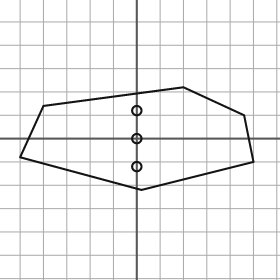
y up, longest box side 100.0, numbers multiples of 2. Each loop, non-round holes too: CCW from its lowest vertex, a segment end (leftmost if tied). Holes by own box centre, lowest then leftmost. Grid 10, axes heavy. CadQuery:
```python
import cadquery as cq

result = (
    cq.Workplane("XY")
    .moveTo(2.0, -22.0)
    .lineTo(50.0, -10.0)
    .lineTo(46.0, 10.0)
    .lineTo(20.0, 22.0)
    .lineTo(-40.0, 14.0)
    .lineTo(-50.0, -8.0)
    .close()
    .moveTo(0.0, -12.0)
    .circle(2.0)
    .moveTo(0.0, 0.0)
    .circle(2.0)
    .moveTo(0.0, 12.0)
    .circle(2.0)
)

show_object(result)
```